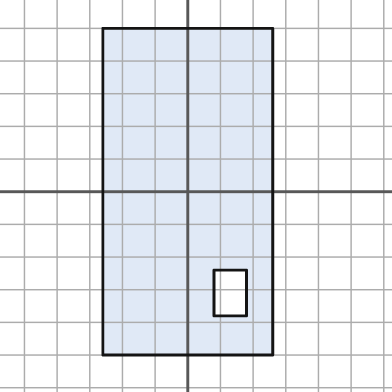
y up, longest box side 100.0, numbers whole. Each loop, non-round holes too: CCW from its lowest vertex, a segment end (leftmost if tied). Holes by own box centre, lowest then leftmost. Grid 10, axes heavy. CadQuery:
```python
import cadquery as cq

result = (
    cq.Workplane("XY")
    .moveTo(-26.0, -50.0)
    .lineTo(26.0, -50.0)
    .lineTo(26.0, 50.0)
    .lineTo(-26.0, 50.0)
    .close()
    .moveTo(8.0, -38.0)
    .lineTo(18.0, -38.0)
    .lineTo(18.0, -24.0)
    .lineTo(8.0, -24.0)
    .close()
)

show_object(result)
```